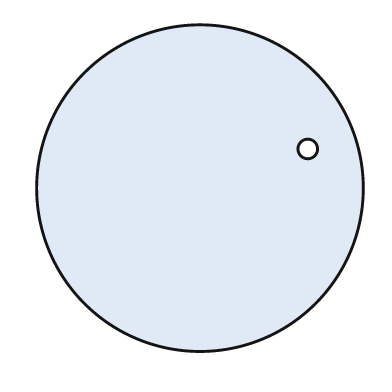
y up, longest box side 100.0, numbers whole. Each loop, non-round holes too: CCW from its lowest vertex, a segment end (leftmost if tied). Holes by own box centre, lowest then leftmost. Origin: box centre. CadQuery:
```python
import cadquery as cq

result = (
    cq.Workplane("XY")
    .moveTo(0.0, 0.0)
    .circle(50.0)
    .moveTo(33.0, 12.0)
    .circle(3.0)
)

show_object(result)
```